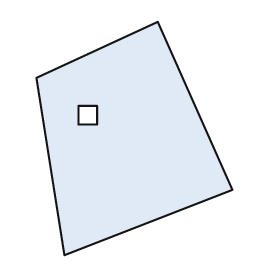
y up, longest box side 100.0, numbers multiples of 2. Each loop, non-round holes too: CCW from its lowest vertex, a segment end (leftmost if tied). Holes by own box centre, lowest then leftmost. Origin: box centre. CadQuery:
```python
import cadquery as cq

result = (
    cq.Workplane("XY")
    .moveTo(-30.0, -50.0)
    .lineTo(42.0, -22.0)
    .lineTo(10.0, 50.0)
    .lineTo(-42.0, 26.0)
    .close()
    .moveTo(-24.0, 6.0)
    .lineTo(-16.0, 6.0)
    .lineTo(-16.0, 14.0)
    .lineTo(-24.0, 14.0)
    .close()
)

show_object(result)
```